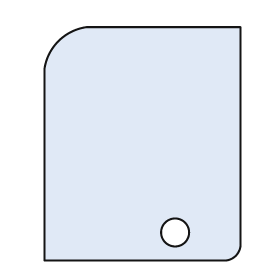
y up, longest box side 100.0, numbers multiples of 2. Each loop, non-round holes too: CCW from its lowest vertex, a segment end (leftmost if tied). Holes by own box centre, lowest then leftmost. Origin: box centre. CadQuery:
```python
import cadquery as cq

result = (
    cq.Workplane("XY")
    .moveTo(-42.0, -50.0)
    .lineTo(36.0, -50.0)
    .threePointArc((40.0, -48.0), (42.0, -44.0))
    .lineTo(42.0, 50.0)
    .lineTo(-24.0, 50.0)
    .threePointArc((-36.0, 44.0), (-42.0, 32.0))
    .close()
    .moveTo(14.0, -38.0)
    .circle(6.0)
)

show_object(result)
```